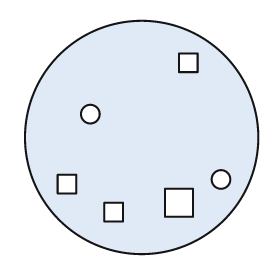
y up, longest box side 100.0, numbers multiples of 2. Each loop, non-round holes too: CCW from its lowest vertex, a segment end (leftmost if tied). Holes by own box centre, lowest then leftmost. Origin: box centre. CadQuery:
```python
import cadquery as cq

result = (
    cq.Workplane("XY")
    .moveTo(0.0, 0.0)
    .circle(50.0)
    .moveTo(-16.0, -36.0)
    .lineTo(-8.0, -36.0)
    .lineTo(-8.0, -28.0)
    .lineTo(-16.0, -28.0)
    .close()
    .moveTo(10.0, -34.0)
    .lineTo(22.0, -34.0)
    .lineTo(22.0, -22.0)
    .lineTo(10.0, -22.0)
    .close()
    .moveTo(-36.0, -24.0)
    .lineTo(-28.0, -24.0)
    .lineTo(-28.0, -16.0)
    .lineTo(-36.0, -16.0)
    .close()
    .moveTo(34.0, -18.0)
    .circle(4.0)
    .moveTo(-22.0, 10.0)
    .circle(4.0)
    .moveTo(16.0, 28.0)
    .lineTo(24.0, 28.0)
    .lineTo(24.0, 36.0)
    .lineTo(16.0, 36.0)
    .close()
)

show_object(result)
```